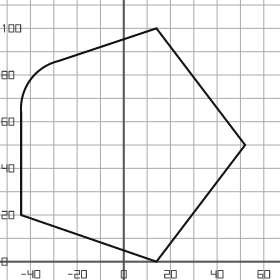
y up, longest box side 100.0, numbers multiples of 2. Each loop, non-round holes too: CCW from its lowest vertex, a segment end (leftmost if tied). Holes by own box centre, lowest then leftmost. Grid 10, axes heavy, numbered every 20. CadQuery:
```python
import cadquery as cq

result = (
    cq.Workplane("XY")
    .moveTo(14.0, 0.0)
    .lineTo(52.0, 50.0)
    .lineTo(14.0, 100.0)
    .lineTo(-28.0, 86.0)
    .threePointArc((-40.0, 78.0), (-44.0, 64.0))
    .lineTo(-44.0, 20.0)
    .close()
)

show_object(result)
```